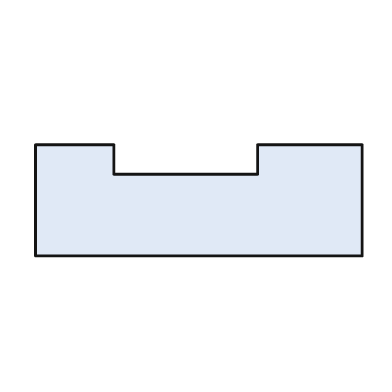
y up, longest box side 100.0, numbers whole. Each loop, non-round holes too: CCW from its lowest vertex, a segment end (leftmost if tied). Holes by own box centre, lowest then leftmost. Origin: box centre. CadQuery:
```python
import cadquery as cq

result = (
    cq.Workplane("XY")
    .moveTo(-50.0, -17.0)
    .lineTo(50.0, -17.0)
    .lineTo(50.0, 17.0)
    .lineTo(18.0, 17.0)
    .lineTo(18.0, 8.0)
    .lineTo(-26.0, 8.0)
    .lineTo(-26.0, 17.0)
    .lineTo(-50.0, 17.0)
    .close()
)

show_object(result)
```